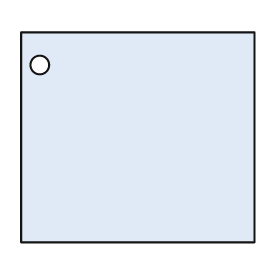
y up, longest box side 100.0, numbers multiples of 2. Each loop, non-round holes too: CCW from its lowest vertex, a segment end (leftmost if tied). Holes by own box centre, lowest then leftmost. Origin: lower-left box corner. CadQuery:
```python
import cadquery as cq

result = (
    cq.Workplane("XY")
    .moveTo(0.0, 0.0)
    .lineTo(100.0, 0.0)
    .lineTo(100.0, 90.0)
    .lineTo(0.0, 90.0)
    .close()
    .moveTo(8.0, 76.0)
    .circle(4.0)
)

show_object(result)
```